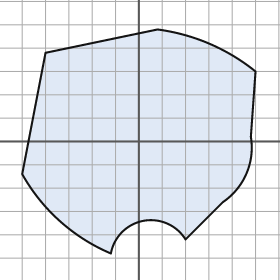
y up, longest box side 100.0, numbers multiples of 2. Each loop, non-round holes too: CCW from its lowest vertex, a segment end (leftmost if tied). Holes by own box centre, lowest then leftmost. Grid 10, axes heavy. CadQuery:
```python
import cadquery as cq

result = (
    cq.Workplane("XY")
    .moveTo(-12.0, -48.0)
    .threePointArc((2.0, -34.0), (20.0, -42.0))
    .lineTo(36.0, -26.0)
    .threePointArc((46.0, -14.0), (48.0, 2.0))
    .lineTo(50.0, 30.0)
    .threePointArc((30.0, 42.0), (8.0, 48.0))
    .lineTo(-40.0, 38.0)
    .lineTo(-50.0, -14.0)
    .threePointArc((-34.0, -34.0), (-12.0, -48.0))
    .close()
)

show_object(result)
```